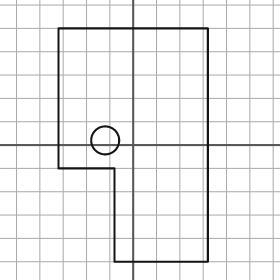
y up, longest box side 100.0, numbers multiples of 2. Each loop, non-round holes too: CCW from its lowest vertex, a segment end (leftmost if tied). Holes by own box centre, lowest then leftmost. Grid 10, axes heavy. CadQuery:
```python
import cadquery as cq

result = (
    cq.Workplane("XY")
    .moveTo(-8.0, -50.0)
    .lineTo(32.0, -50.0)
    .lineTo(32.0, 50.0)
    .lineTo(-32.0, 50.0)
    .lineTo(-32.0, -10.0)
    .lineTo(-8.0, -10.0)
    .close()
    .moveTo(-12.0, 2.0)
    .circle(6.0)
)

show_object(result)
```